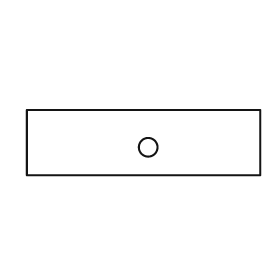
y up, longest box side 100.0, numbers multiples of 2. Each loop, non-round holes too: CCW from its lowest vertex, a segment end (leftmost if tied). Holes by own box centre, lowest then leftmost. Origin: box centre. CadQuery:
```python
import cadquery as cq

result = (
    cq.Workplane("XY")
    .moveTo(-50.0, -14.0)
    .lineTo(50.0, -14.0)
    .lineTo(50.0, 14.0)
    .lineTo(-50.0, 14.0)
    .close()
    .moveTo(2.0, -2.0)
    .circle(4.0)
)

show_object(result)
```